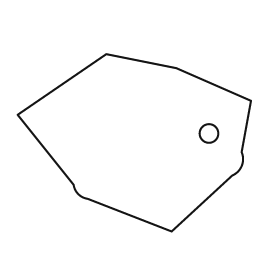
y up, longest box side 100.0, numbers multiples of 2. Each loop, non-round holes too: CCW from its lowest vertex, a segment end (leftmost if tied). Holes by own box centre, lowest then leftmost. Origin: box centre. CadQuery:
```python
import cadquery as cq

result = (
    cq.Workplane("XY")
    .moveTo(16.0, -38.0)
    .lineTo(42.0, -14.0)
    .threePointArc((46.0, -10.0), (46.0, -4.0))
    .lineTo(50.0, 18.0)
    .lineTo(18.0, 32.0)
    .lineTo(-12.0, 38.0)
    .lineTo(-50.0, 12.0)
    .lineTo(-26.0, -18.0)
    .threePointArc((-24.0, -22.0), (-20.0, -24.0))
    .close()
    .moveTo(32.0, 4.0)
    .circle(4.0)
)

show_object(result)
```